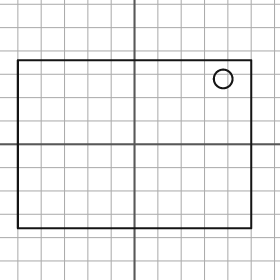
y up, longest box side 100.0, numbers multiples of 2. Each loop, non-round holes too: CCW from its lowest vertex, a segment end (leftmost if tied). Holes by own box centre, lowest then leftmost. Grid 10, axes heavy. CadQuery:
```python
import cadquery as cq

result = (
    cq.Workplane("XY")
    .moveTo(-50.0, -36.0)
    .lineTo(50.0, -36.0)
    .lineTo(50.0, 36.0)
    .lineTo(-50.0, 36.0)
    .close()
    .moveTo(38.0, 28.0)
    .circle(4.0)
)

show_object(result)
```